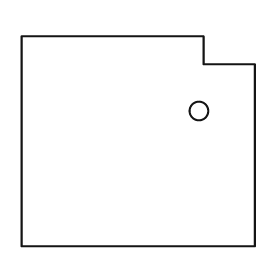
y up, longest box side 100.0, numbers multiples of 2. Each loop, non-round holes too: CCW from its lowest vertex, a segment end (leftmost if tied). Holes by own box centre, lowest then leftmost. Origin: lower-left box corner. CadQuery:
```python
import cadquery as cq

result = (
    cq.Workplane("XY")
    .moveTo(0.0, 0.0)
    .lineTo(100.0, 0.0)
    .lineTo(100.0, 78.0)
    .lineTo(78.0, 78.0)
    .lineTo(78.0, 90.0)
    .lineTo(0.0, 90.0)
    .close()
    .moveTo(76.0, 58.0)
    .circle(4.0)
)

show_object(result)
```